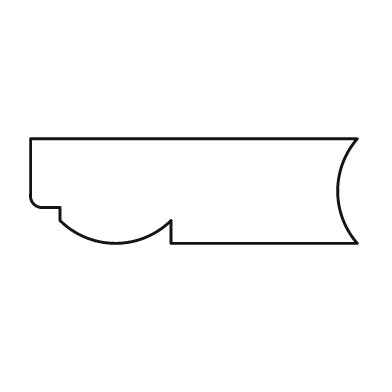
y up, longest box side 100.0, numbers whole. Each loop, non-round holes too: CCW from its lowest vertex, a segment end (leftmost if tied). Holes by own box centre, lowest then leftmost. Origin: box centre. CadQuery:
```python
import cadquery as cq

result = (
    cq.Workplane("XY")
    .moveTo(-7.0, -16.0)
    .lineTo(50.0, -16.0)
    .threePointArc((44.0, 0.0), (50.0, 16.0))
    .lineTo(-50.0, 16.0)
    .lineTo(-50.0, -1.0)
    .threePointArc((-49.0, -4.0), (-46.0, -5.0))
    .lineTo(-41.0, -5.0)
    .lineTo(-41.0, -9.0)
    .threePointArc((-24.0, -16.0), (-7.0, -9.0))
    .close()
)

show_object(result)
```